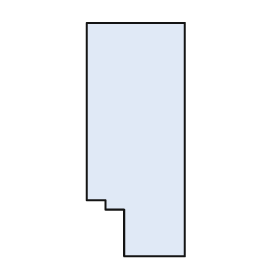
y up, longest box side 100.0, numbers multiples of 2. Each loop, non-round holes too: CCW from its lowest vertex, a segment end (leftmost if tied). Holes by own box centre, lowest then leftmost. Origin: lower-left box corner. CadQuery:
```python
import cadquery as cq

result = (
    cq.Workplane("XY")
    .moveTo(16.0, 0.0)
    .lineTo(42.0, 0.0)
    .lineTo(42.0, 100.0)
    .lineTo(0.0, 100.0)
    .lineTo(0.0, 24.0)
    .lineTo(8.0, 24.0)
    .lineTo(8.0, 20.0)
    .lineTo(16.0, 20.0)
    .close()
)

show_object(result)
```